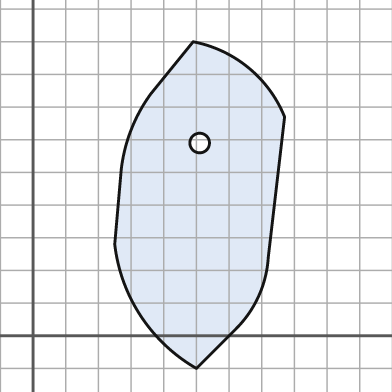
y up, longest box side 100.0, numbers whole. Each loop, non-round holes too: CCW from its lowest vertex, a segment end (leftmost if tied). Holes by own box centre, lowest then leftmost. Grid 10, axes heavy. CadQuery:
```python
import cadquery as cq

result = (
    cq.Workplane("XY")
    .moveTo(50.0, -10.0)
    .lineTo(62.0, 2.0)
    .threePointArc((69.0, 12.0), (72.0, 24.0))
    .lineTo(77.0, 67.0)
    .threePointArc((66.0, 82.0), (49.0, 90.0))
    .lineTo(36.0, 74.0)
    .threePointArc((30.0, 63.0), (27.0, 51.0))
    .lineTo(25.0, 28.0)
    .threePointArc((33.0, 6.0), (50.0, -10.0))
    .close()
    .moveTo(51.0, 59.0)
    .circle(3.0)
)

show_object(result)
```